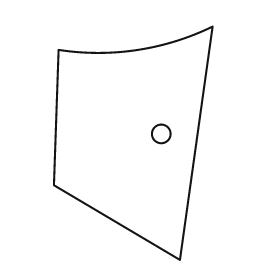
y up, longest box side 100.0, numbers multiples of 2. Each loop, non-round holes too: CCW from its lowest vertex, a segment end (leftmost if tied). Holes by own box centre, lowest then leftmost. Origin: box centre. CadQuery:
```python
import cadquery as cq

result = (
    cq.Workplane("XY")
    .moveTo(20.0, -50.0)
    .lineTo(34.0, 50.0)
    .threePointArc((2.0, 40.0), (-32.0, 40.0))
    .lineTo(-34.0, -18.0)
    .close()
    .moveTo(12.0, 4.0)
    .circle(4.0)
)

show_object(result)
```